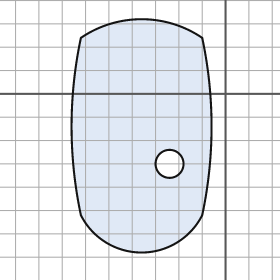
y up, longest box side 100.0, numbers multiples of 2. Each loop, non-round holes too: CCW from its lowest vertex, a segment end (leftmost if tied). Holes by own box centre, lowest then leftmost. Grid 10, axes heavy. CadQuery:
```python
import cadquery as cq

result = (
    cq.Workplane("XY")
    .moveTo(-62.0, -52.0)
    .threePointArc((-36.0, -68.0), (-10.0, -52.0))
    .threePointArc((-6.0, -14.0), (-10.0, 24.0))
    .threePointArc((-36.0, 32.0), (-62.0, 24.0))
    .threePointArc((-66.0, -14.0), (-62.0, -52.0))
    .close()
    .moveTo(-24.0, -30.0)
    .circle(6.0)
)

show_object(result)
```